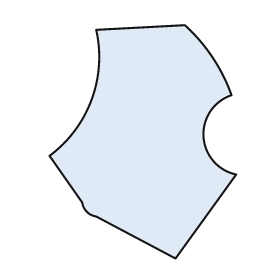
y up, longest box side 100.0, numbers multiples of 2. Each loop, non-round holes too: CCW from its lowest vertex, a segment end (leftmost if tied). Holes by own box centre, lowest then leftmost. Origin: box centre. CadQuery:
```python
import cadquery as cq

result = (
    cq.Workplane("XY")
    .moveTo(14.0, -50.0)
    .lineTo(40.0, -14.0)
    .threePointArc((26.0, 2.0), (38.0, 20.0))
    .threePointArc((30.0, 36.0), (18.0, 50.0))
    .lineTo(-20.0, 48.0)
    .threePointArc((-22.0, 18.0), (-40.0, -6.0))
    .lineTo(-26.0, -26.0)
    .threePointArc((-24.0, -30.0), (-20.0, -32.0))
    .close()
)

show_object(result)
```